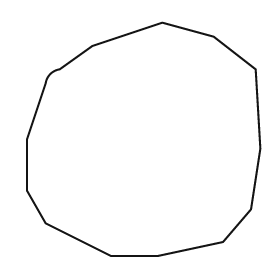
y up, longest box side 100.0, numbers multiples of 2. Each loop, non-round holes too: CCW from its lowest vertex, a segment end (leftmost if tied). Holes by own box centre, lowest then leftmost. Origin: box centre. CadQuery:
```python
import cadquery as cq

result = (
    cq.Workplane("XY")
    .moveTo(-14.0, -50.0)
    .lineTo(6.0, -50.0)
    .lineTo(34.0, -44.0)
    .lineTo(46.0, -30.0)
    .lineTo(50.0, -4.0)
    .lineTo(48.0, 30.0)
    .lineTo(30.0, 44.0)
    .lineTo(8.0, 50.0)
    .lineTo(-22.0, 40.0)
    .lineTo(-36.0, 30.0)
    .threePointArc((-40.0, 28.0), (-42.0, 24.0))
    .lineTo(-50.0, 0.0)
    .lineTo(-50.0, -22.0)
    .lineTo(-42.0, -36.0)
    .close()
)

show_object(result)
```